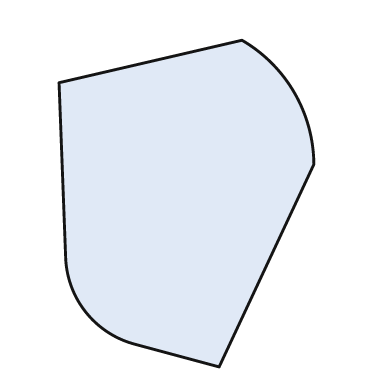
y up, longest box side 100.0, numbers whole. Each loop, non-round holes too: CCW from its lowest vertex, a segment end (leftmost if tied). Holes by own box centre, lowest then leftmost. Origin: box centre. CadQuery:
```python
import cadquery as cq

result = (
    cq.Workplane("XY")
    .moveTo(10.0, -50.0)
    .lineTo(39.0, 12.0)
    .threePointArc((33.0, 34.0), (17.0, 50.0))
    .lineTo(-39.0, 37.0)
    .lineTo(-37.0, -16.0)
    .threePointArc((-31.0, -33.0), (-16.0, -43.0))
    .close()
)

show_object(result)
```